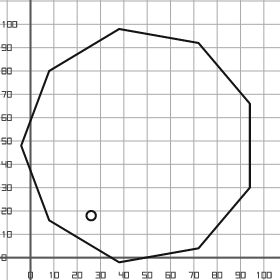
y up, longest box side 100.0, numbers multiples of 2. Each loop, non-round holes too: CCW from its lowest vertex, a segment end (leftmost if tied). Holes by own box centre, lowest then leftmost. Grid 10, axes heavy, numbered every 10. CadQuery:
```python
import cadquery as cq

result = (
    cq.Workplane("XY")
    .moveTo(38.0, -2.0)
    .lineTo(72.0, 4.0)
    .lineTo(94.0, 30.0)
    .lineTo(94.0, 66.0)
    .lineTo(72.0, 92.0)
    .lineTo(38.0, 98.0)
    .lineTo(8.0, 80.0)
    .lineTo(-4.0, 48.0)
    .lineTo(8.0, 16.0)
    .close()
    .moveTo(26.0, 18.0)
    .circle(2.0)
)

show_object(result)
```